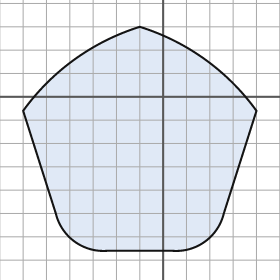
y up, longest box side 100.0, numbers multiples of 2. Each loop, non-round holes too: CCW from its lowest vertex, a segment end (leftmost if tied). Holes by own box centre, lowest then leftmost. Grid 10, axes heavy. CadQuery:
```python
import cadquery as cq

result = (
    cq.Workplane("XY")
    .moveTo(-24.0, -66.0)
    .lineTo(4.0, -66.0)
    .threePointArc((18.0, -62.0), (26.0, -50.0))
    .lineTo(40.0, -6.0)
    .threePointArc((18.0, 16.0), (-10.0, 30.0))
    .threePointArc((-38.0, 16.0), (-60.0, -6.0))
    .lineTo(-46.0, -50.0)
    .threePointArc((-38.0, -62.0), (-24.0, -66.0))
    .close()
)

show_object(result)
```